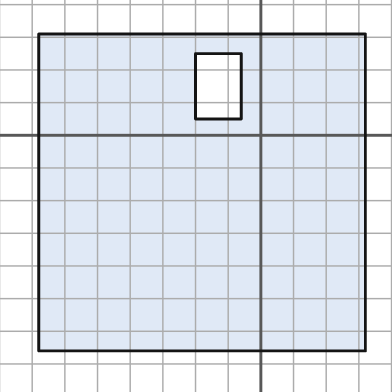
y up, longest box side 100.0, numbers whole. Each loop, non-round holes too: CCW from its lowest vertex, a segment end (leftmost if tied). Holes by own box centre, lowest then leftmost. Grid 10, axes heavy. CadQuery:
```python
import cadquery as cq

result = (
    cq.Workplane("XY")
    .moveTo(-68.0, -66.0)
    .lineTo(32.0, -66.0)
    .lineTo(32.0, 31.0)
    .lineTo(-68.0, 31.0)
    .close()
    .moveTo(-20.0, 5.0)
    .lineTo(-6.0, 5.0)
    .lineTo(-6.0, 25.0)
    .lineTo(-20.0, 25.0)
    .close()
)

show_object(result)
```